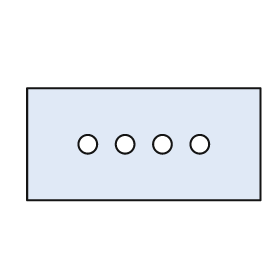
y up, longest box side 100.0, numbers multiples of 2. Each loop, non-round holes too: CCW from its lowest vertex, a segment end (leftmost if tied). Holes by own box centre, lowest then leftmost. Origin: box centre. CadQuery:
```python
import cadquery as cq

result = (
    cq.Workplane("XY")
    .moveTo(-50.0, -24.0)
    .lineTo(50.0, -24.0)
    .lineTo(50.0, 24.0)
    .lineTo(-50.0, 24.0)
    .close()
    .moveTo(-24.0, 0.0)
    .circle(4.0)
    .moveTo(-8.0, 0.0)
    .circle(4.0)
    .moveTo(8.0, 0.0)
    .circle(4.0)
    .moveTo(24.0, 0.0)
    .circle(4.0)
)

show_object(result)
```